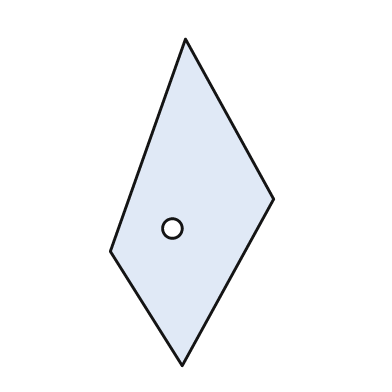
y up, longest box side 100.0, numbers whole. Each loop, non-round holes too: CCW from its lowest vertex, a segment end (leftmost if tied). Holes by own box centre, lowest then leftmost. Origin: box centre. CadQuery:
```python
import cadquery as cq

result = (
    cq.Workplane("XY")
    .moveTo(-3.0, -50.0)
    .lineTo(25.0, 1.0)
    .lineTo(-2.0, 50.0)
    .lineTo(-25.0, -15.0)
    .close()
    .moveTo(-6.0, -8.0)
    .circle(3.0)
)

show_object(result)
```